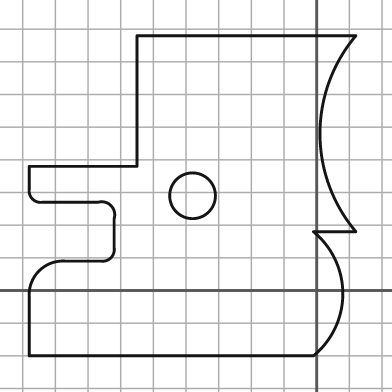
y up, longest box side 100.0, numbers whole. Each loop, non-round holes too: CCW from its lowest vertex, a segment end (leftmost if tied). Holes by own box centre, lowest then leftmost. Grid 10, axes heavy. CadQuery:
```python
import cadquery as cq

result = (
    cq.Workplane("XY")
    .moveTo(-88.0, -20.0)
    .lineTo(-1.0, -20.0)
    .threePointArc((8.0, -1.0), (-1.0, 18.0))
    .lineTo(12.0, 18.0)
    .threePointArc((1.0, 48.0), (12.0, 78.0))
    .lineTo(-55.0, 78.0)
    .lineTo(-55.0, 38.0)
    .lineTo(-88.0, 38.0)
    .lineTo(-88.0, 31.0)
    .threePointArc((-87.0, 28.0), (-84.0, 27.0))
    .lineTo(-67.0, 27.0)
    .threePointArc((-63.0, 26.0), (-62.0, 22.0))
    .lineTo(-62.0, 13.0)
    .threePointArc((-63.0, 10.0), (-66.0, 9.0))
    .lineTo(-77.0, 9.0)
    .threePointArc((-85.0, 6.0), (-88.0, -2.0))
    .close()
    .moveTo(-38.0, 29.0)
    .circle(7.0)
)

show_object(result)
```